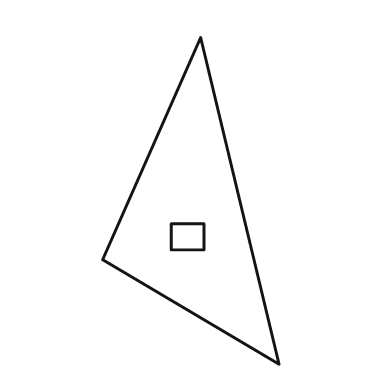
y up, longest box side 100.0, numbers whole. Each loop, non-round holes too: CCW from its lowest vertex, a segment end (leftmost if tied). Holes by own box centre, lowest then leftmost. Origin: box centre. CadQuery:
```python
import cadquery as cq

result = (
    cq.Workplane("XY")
    .moveTo(27.0, -50.0)
    .lineTo(3.0, 50.0)
    .lineTo(-27.0, -18.0)
    .close()
    .moveTo(-6.0, -15.0)
    .lineTo(4.0, -15.0)
    .lineTo(4.0, -7.0)
    .lineTo(-6.0, -7.0)
    .close()
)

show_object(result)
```